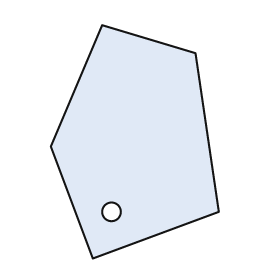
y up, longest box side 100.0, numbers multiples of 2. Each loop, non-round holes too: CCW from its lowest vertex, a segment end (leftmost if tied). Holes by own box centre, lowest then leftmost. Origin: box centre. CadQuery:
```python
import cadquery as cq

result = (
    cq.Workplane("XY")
    .moveTo(-18.0, -50.0)
    .lineTo(36.0, -30.0)
    .lineTo(26.0, 38.0)
    .lineTo(-14.0, 50.0)
    .lineTo(-36.0, -2.0)
    .close()
    .moveTo(-10.0, -30.0)
    .circle(4.0)
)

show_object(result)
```